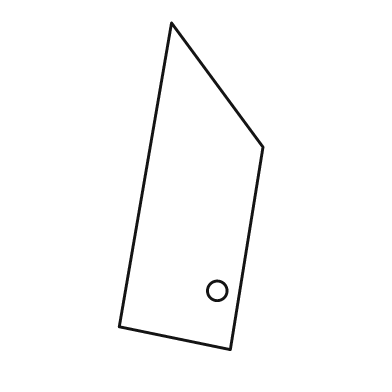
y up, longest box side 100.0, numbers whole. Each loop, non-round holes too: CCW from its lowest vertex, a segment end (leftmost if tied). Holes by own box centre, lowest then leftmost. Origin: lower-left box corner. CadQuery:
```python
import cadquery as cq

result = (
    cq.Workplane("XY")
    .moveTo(34.0, 0.0)
    .lineTo(44.0, 62.0)
    .lineTo(16.0, 100.0)
    .lineTo(0.0, 7.0)
    .close()
    .moveTo(30.0, 18.0)
    .circle(3.0)
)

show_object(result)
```